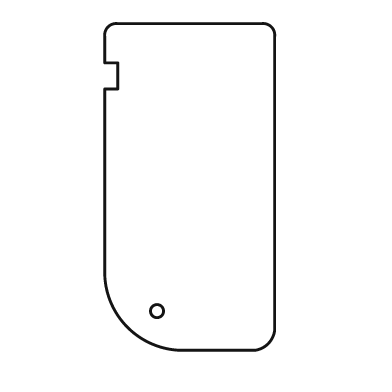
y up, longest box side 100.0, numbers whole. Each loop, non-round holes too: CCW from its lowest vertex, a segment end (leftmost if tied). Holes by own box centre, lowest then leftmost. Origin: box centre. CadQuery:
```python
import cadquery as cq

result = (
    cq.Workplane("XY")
    .moveTo(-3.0, -50.0)
    .lineTo(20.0, -50.0)
    .threePointArc((24.0, -48.0), (26.0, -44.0))
    .lineTo(26.0, 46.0)
    .threePointArc((25.0, 49.0), (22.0, 50.0))
    .lineTo(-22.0, 50.0)
    .threePointArc((-25.0, 49.0), (-26.0, 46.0))
    .lineTo(-26.0, 38.0)
    .lineTo(-22.0, 38.0)
    .lineTo(-22.0, 30.0)
    .lineTo(-26.0, 30.0)
    .lineTo(-26.0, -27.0)
    .threePointArc((-19.0, -43.0), (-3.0, -50.0))
    .close()
    .moveTo(-10.0, -38.0)
    .circle(2.0)
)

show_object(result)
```